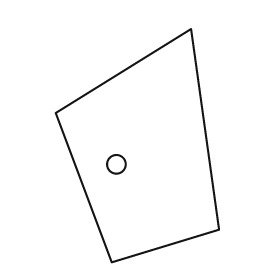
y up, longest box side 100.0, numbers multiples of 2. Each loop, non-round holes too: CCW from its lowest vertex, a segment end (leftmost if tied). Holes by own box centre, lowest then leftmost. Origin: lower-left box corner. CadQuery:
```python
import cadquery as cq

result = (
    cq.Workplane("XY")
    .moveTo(24.0, 0.0)
    .lineTo(70.0, 14.0)
    .lineTo(58.0, 100.0)
    .lineTo(0.0, 64.0)
    .close()
    .moveTo(26.0, 42.0)
    .circle(4.0)
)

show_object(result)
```